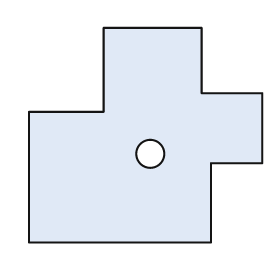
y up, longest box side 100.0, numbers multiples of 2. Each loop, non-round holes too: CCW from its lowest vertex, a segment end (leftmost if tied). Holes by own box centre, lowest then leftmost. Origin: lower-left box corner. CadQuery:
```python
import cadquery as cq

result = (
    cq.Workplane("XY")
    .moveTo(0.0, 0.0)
    .lineTo(78.0, 0.0)
    .lineTo(78.0, 34.0)
    .lineTo(100.0, 34.0)
    .lineTo(100.0, 64.0)
    .lineTo(74.0, 64.0)
    .lineTo(74.0, 92.0)
    .lineTo(32.0, 92.0)
    .lineTo(32.0, 56.0)
    .lineTo(0.0, 56.0)
    .close()
    .moveTo(52.0, 38.0)
    .circle(6.0)
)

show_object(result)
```